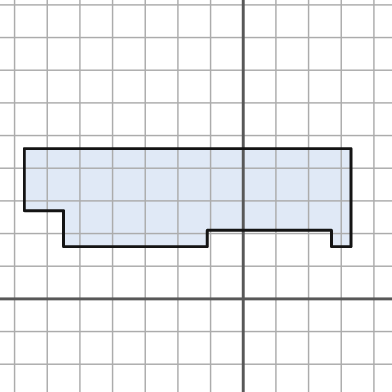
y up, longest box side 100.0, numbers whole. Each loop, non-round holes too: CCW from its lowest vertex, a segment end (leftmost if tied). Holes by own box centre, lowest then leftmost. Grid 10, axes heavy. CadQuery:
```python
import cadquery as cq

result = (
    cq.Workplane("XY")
    .moveTo(-55.0, 16.0)
    .lineTo(-11.0, 16.0)
    .lineTo(-11.0, 21.0)
    .lineTo(27.0, 21.0)
    .lineTo(27.0, 16.0)
    .lineTo(33.0, 16.0)
    .lineTo(33.0, 46.0)
    .lineTo(-67.0, 46.0)
    .lineTo(-67.0, 27.0)
    .lineTo(-55.0, 27.0)
    .close()
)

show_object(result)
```